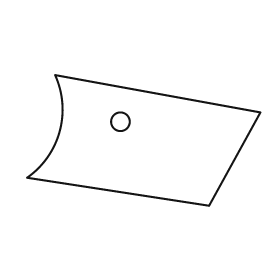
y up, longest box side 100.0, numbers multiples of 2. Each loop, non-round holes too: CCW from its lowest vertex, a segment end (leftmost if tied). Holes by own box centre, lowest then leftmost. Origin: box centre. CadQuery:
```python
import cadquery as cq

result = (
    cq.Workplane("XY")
    .moveTo(28.0, -28.0)
    .lineTo(50.0, 12.0)
    .lineTo(-38.0, 28.0)
    .threePointArc((-36.0, 4.0), (-50.0, -16.0))
    .close()
    .moveTo(-10.0, 8.0)
    .circle(4.0)
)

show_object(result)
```